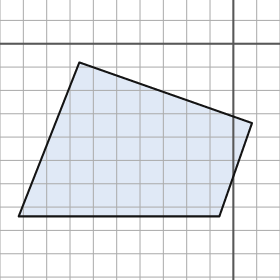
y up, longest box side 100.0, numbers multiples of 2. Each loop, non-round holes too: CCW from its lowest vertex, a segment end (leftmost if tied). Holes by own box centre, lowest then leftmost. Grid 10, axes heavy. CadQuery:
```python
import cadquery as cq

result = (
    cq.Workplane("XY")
    .moveTo(-92.0, -74.0)
    .lineTo(-6.0, -74.0)
    .lineTo(8.0, -34.0)
    .lineTo(-66.0, -8.0)
    .close()
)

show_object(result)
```